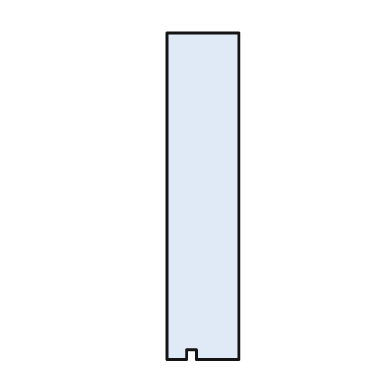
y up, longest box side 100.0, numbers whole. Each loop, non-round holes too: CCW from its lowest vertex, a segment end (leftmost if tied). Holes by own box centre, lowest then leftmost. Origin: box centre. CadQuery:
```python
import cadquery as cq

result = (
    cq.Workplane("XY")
    .moveTo(-11.0, -50.0)
    .lineTo(-5.0, -50.0)
    .lineTo(-5.0, -47.0)
    .lineTo(-2.0, -47.0)
    .lineTo(-2.0, -50.0)
    .lineTo(11.0, -50.0)
    .lineTo(11.0, 50.0)
    .lineTo(-11.0, 50.0)
    .close()
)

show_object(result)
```